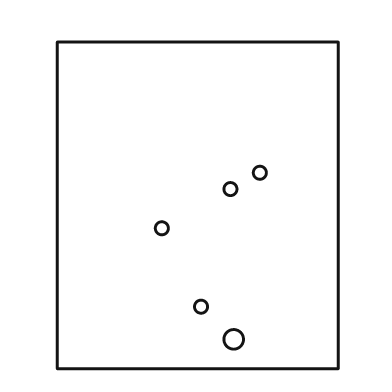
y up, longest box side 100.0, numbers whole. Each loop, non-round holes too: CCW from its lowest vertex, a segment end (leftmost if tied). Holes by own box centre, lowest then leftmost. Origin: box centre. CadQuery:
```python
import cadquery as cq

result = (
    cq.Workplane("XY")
    .moveTo(-43.0, -50.0)
    .lineTo(43.0, -50.0)
    .lineTo(43.0, 50.0)
    .lineTo(-43.0, 50.0)
    .close()
    .moveTo(11.0, -41.0)
    .circle(3.0)
    .moveTo(1.0, -31.0)
    .circle(2.0)
    .moveTo(-11.0, -7.0)
    .circle(2.0)
    .moveTo(10.0, 5.0)
    .circle(2.0)
    .moveTo(19.0, 10.0)
    .circle(2.0)
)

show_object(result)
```